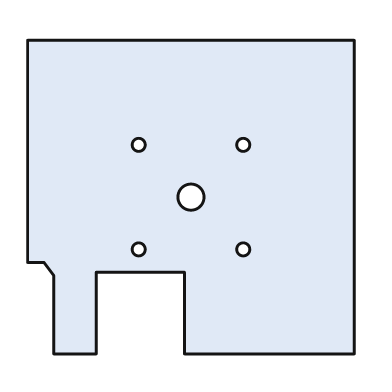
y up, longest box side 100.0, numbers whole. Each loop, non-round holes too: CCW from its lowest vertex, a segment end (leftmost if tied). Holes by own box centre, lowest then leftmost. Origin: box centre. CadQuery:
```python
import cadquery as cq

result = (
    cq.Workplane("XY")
    .moveTo(-42.0, -48.0)
    .lineTo(-29.0, -48.0)
    .lineTo(-29.0, -23.0)
    .lineTo(-2.0, -23.0)
    .lineTo(-2.0, -48.0)
    .lineTo(50.0, -48.0)
    .lineTo(50.0, 48.0)
    .lineTo(-50.0, 48.0)
    .lineTo(-50.0, -20.0)
    .lineTo(-45.0, -20.0)
    .lineTo(-42.0, -24.0)
    .close()
    .moveTo(-16.0, -16.0)
    .circle(2.0)
    .moveTo(16.0, -16.0)
    .circle(2.0)
    .moveTo(0.0, 0.0)
    .circle(4.0)
    .moveTo(-16.0, 16.0)
    .circle(2.0)
    .moveTo(16.0, 16.0)
    .circle(2.0)
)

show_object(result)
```